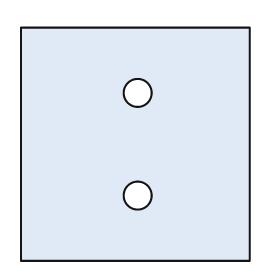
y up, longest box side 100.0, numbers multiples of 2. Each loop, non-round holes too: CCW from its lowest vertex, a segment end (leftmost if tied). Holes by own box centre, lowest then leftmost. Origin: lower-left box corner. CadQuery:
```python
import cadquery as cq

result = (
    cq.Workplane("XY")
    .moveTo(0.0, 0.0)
    .lineTo(98.0, 0.0)
    .lineTo(98.0, 100.0)
    .lineTo(0.0, 100.0)
    .close()
    .moveTo(50.0, 28.0)
    .circle(6.0)
    .moveTo(50.0, 72.0)
    .circle(6.0)
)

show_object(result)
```